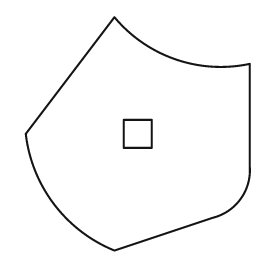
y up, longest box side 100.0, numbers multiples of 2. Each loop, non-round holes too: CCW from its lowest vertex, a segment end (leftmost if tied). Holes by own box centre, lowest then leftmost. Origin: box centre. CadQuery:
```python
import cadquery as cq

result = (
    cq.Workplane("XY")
    .moveTo(-10.0, -50.0)
    .lineTo(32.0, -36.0)
    .threePointArc((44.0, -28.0), (48.0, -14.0))
    .lineTo(48.0, 30.0)
    .threePointArc((16.0, 32.0), (-10.0, 50.0))
    .lineTo(-48.0, 0.0)
    .threePointArc((-36.0, -30.0), (-10.0, -50.0))
    .close()
    .moveTo(-6.0, -6.0)
    .lineTo(6.0, -6.0)
    .lineTo(6.0, 6.0)
    .lineTo(-6.0, 6.0)
    .close()
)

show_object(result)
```